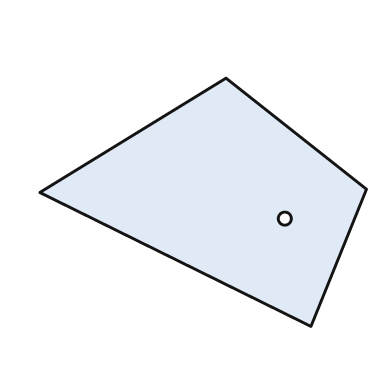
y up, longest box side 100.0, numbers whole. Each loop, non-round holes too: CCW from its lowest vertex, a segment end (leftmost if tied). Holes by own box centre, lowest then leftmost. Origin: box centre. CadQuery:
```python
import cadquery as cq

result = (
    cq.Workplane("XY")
    .moveTo(33.0, -38.0)
    .lineTo(50.0, 4.0)
    .lineTo(7.0, 38.0)
    .lineTo(-50.0, 3.0)
    .close()
    .moveTo(25.0, -5.0)
    .circle(2.0)
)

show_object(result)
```